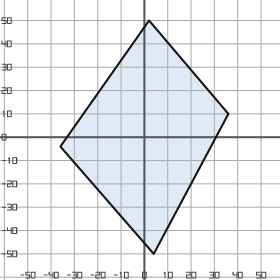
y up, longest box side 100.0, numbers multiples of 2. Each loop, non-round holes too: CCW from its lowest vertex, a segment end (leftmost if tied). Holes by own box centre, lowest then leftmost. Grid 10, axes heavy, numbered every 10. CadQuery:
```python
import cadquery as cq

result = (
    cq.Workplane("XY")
    .moveTo(4.0, -50.0)
    .lineTo(36.0, 10.0)
    .lineTo(2.0, 50.0)
    .lineTo(-36.0, -4.0)
    .close()
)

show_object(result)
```